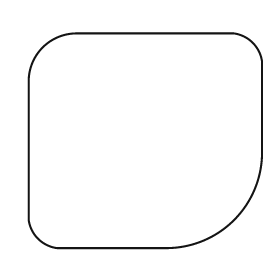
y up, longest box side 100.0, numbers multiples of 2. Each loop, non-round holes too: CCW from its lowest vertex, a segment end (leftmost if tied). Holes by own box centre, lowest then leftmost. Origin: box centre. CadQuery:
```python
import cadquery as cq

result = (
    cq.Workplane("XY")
    .moveTo(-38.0, -46.0)
    .lineTo(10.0, -46.0)
    .threePointArc((38.0, -34.0), (50.0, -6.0))
    .lineTo(50.0, 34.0)
    .threePointArc((46.0, 42.0), (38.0, 46.0))
    .lineTo(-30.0, 46.0)
    .threePointArc((-44.0, 40.0), (-50.0, 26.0))
    .lineTo(-50.0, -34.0)
    .threePointArc((-46.0, -42.0), (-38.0, -46.0))
    .close()
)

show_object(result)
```